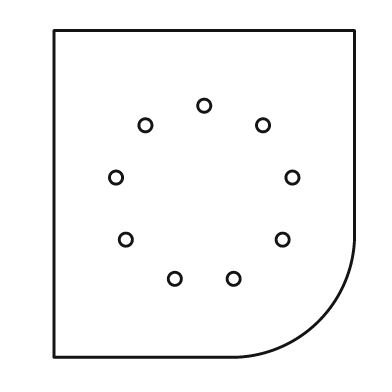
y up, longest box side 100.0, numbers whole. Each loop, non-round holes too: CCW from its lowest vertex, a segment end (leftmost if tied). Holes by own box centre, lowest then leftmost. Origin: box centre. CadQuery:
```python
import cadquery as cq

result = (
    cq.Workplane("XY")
    .moveTo(-46.0, -50.0)
    .lineTo(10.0, -50.0)
    .threePointArc((35.0, -39.0), (46.0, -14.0))
    .lineTo(46.0, 50.0)
    .lineTo(-46.0, 50.0)
    .close()
    .moveTo(-9.0, -26.0)
    .circle(2.0)
    .moveTo(9.0, -26.0)
    .circle(2.0)
    .moveTo(-24.0, -14.0)
    .circle(2.0)
    .moveTo(24.0, -14.0)
    .circle(2.0)
    .moveTo(-27.0, 5.0)
    .circle(2.0)
    .moveTo(27.0, 5.0)
    .circle(2.0)
    .moveTo(-18.0, 21.0)
    .circle(2.0)
    .moveTo(18.0, 21.0)
    .circle(2.0)
    .moveTo(0.0, 27.0)
    .circle(2.0)
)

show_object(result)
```